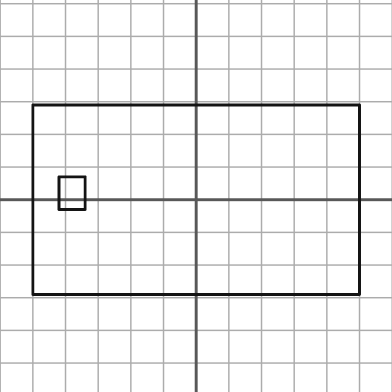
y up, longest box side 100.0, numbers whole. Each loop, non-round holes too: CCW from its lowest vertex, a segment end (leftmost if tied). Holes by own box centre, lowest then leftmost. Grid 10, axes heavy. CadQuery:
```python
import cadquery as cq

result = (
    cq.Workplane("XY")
    .moveTo(-50.0, -29.0)
    .lineTo(50.0, -29.0)
    .lineTo(50.0, 29.0)
    .lineTo(-50.0, 29.0)
    .close()
    .moveTo(-42.0, -3.0)
    .lineTo(-34.0, -3.0)
    .lineTo(-34.0, 7.0)
    .lineTo(-42.0, 7.0)
    .close()
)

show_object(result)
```